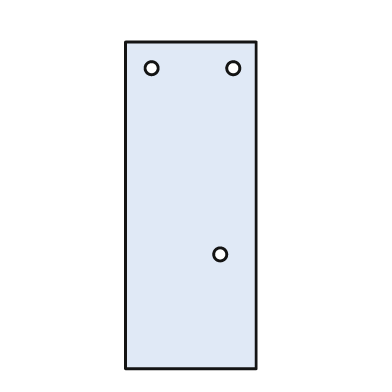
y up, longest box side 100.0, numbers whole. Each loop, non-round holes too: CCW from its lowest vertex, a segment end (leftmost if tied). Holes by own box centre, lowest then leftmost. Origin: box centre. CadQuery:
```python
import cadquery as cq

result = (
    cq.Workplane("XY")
    .moveTo(-20.0, -50.0)
    .lineTo(20.0, -50.0)
    .lineTo(20.0, 50.0)
    .lineTo(-20.0, 50.0)
    .close()
    .moveTo(9.0, -15.0)
    .circle(2.0)
    .moveTo(-12.0, 42.0)
    .circle(2.0)
    .moveTo(13.0, 42.0)
    .circle(2.0)
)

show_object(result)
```